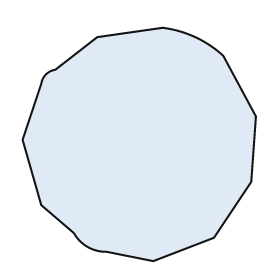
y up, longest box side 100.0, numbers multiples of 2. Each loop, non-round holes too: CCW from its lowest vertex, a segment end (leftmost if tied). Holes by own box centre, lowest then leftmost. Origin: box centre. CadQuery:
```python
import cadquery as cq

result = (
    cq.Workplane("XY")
    .moveTo(6.0, -50.0)
    .lineTo(32.0, -40.0)
    .lineTo(48.0, -16.0)
    .lineTo(50.0, 12.0)
    .lineTo(36.0, 38.0)
    .threePointArc((24.0, 46.0), (10.0, 50.0))
    .lineTo(-18.0, 46.0)
    .lineTo(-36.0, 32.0)
    .threePointArc((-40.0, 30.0), (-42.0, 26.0))
    .lineTo(-50.0, 2.0)
    .lineTo(-42.0, -26.0)
    .lineTo(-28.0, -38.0)
    .threePointArc((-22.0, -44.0), (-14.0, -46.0))
    .close()
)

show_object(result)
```